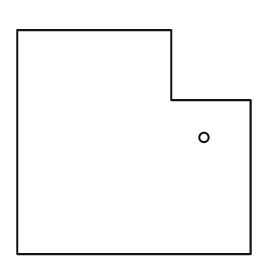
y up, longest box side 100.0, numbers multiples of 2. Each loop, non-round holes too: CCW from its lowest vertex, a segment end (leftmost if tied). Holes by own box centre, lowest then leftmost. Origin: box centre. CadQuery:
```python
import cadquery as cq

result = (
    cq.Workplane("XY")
    .moveTo(-50.0, -48.0)
    .lineTo(50.0, -48.0)
    .lineTo(50.0, 18.0)
    .lineTo(16.0, 18.0)
    .lineTo(16.0, 48.0)
    .lineTo(-50.0, 48.0)
    .close()
    .moveTo(30.0, 2.0)
    .circle(2.0)
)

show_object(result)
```